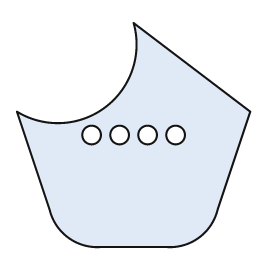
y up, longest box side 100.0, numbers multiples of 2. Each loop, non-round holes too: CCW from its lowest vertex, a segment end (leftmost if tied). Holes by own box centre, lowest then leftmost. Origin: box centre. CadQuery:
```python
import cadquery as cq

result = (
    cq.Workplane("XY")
    .moveTo(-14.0, -48.0)
    .lineTo(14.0, -48.0)
    .threePointArc((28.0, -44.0), (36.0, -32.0))
    .lineTo(50.0, 10.0)
    .lineTo(0.0, 48.0)
    .threePointArc((-12.0, 12.0), (-50.0, 10.0))
    .lineTo(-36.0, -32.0)
    .threePointArc((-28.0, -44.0), (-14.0, -48.0))
    .close()
    .moveTo(-18.0, 0.0)
    .circle(4.0)
    .moveTo(-6.0, 0.0)
    .circle(4.0)
    .moveTo(6.0, 0.0)
    .circle(4.0)
    .moveTo(18.0, 0.0)
    .circle(4.0)
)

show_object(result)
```